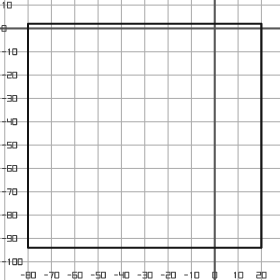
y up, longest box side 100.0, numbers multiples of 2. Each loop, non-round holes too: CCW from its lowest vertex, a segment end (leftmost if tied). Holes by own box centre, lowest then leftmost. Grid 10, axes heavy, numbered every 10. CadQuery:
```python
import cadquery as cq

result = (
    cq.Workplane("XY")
    .moveTo(-80.0, -94.0)
    .lineTo(20.0, -94.0)
    .lineTo(20.0, 2.0)
    .lineTo(-80.0, 2.0)
    .close()
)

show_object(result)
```